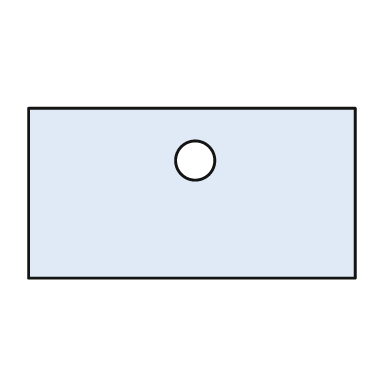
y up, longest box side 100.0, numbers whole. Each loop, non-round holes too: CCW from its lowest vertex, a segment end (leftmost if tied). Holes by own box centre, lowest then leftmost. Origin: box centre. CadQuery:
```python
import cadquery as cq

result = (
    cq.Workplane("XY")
    .moveTo(-50.0, -26.0)
    .lineTo(50.0, -26.0)
    .lineTo(50.0, 26.0)
    .lineTo(-50.0, 26.0)
    .close()
    .moveTo(1.0, 10.0)
    .circle(6.0)
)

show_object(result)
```